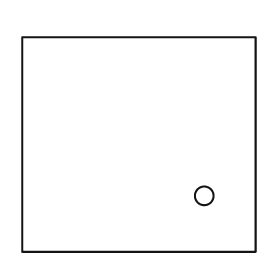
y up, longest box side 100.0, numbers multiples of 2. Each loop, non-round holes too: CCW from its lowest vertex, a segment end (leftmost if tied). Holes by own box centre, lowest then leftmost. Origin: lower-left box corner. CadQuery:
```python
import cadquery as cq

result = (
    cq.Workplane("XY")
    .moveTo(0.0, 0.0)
    .lineTo(100.0, 0.0)
    .lineTo(100.0, 92.0)
    .lineTo(0.0, 92.0)
    .close()
    .moveTo(78.0, 24.0)
    .circle(4.0)
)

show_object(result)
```